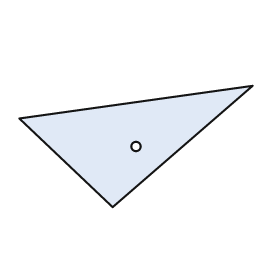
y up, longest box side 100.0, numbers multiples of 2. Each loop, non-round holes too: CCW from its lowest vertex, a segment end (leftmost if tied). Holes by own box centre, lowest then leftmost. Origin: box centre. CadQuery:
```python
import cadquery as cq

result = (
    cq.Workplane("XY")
    .moveTo(-10.0, -26.0)
    .lineTo(50.0, 26.0)
    .lineTo(-50.0, 12.0)
    .close()
    .moveTo(0.0, 0.0)
    .circle(2.0)
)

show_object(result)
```